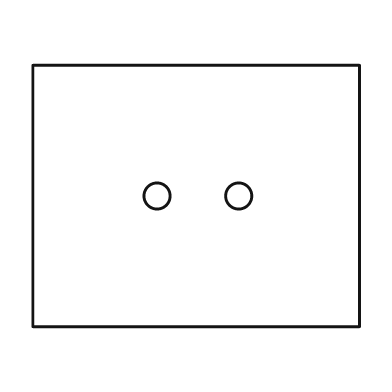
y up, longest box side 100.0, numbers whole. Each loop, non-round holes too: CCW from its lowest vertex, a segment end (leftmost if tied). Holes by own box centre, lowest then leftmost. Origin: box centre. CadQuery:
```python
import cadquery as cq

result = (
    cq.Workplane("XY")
    .moveTo(-50.0, -40.0)
    .lineTo(50.0, -40.0)
    .lineTo(50.0, 40.0)
    .lineTo(-50.0, 40.0)
    .close()
    .moveTo(-12.0, 0.0)
    .circle(4.0)
    .moveTo(13.0, 0.0)
    .circle(4.0)
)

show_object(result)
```